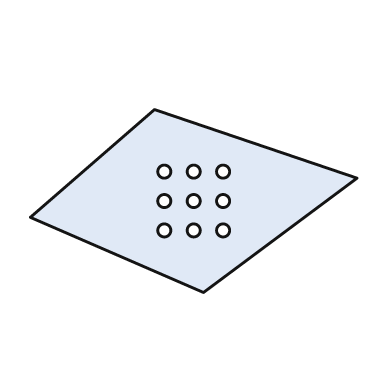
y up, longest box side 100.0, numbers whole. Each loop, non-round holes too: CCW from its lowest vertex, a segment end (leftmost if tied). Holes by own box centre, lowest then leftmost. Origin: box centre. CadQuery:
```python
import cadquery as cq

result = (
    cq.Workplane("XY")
    .moveTo(3.0, -28.0)
    .lineTo(50.0, 7.0)
    .lineTo(-12.0, 28.0)
    .lineTo(-50.0, -5.0)
    .close()
    .moveTo(-9.0, -9.0)
    .circle(2.0)
    .moveTo(0.0, -9.0)
    .circle(2.0)
    .moveTo(9.0, -9.0)
    .circle(2.0)
    .moveTo(-9.0, 0.0)
    .circle(2.0)
    .moveTo(0.0, 0.0)
    .circle(2.0)
    .moveTo(9.0, 0.0)
    .circle(2.0)
    .moveTo(-9.0, 9.0)
    .circle(2.0)
    .moveTo(0.0, 9.0)
    .circle(2.0)
    .moveTo(9.0, 9.0)
    .circle(2.0)
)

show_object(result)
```